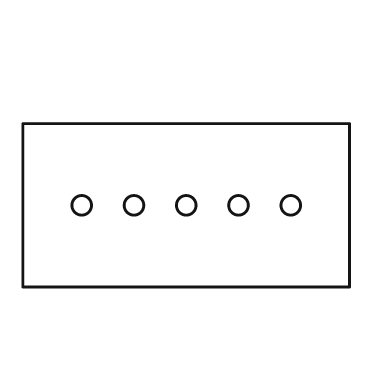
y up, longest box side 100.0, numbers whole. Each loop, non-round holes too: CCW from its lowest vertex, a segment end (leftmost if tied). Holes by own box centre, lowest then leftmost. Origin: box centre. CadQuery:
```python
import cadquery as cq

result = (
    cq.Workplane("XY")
    .moveTo(-50.0, -25.0)
    .lineTo(50.0, -25.0)
    .lineTo(50.0, 25.0)
    .lineTo(-50.0, 25.0)
    .close()
    .moveTo(-32.0, 0.0)
    .circle(3.0)
    .moveTo(-16.0, 0.0)
    .circle(3.0)
    .moveTo(0.0, 0.0)
    .circle(3.0)
    .moveTo(16.0, 0.0)
    .circle(3.0)
    .moveTo(32.0, 0.0)
    .circle(3.0)
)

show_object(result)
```